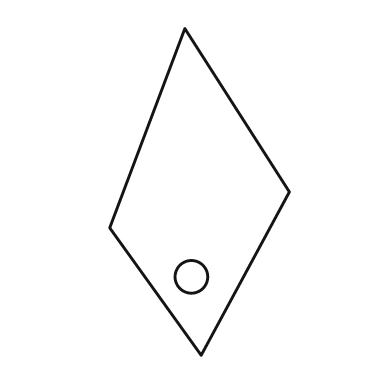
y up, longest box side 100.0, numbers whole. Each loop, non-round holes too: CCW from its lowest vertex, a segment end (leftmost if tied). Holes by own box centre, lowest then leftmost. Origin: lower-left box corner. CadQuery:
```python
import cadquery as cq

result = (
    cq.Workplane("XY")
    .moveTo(28.0, 0.0)
    .lineTo(55.0, 50.0)
    .lineTo(23.0, 100.0)
    .lineTo(0.0, 39.0)
    .close()
    .moveTo(25.0, 24.0)
    .circle(5.0)
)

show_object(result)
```